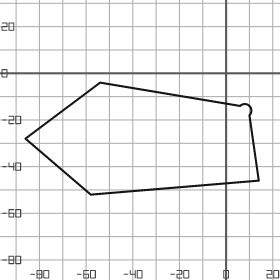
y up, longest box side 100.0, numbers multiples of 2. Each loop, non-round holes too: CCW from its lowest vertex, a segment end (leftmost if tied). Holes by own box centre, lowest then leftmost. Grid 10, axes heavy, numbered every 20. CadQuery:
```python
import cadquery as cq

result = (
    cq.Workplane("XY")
    .moveTo(-58.0, -52.0)
    .lineTo(14.0, -46.0)
    .lineTo(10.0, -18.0)
    .threePointArc((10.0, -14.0), (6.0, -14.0))
    .lineTo(-54.0, -4.0)
    .lineTo(-86.0, -28.0)
    .close()
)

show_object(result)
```